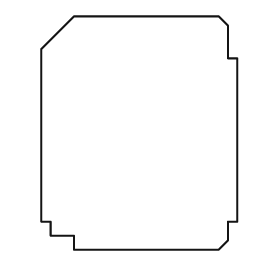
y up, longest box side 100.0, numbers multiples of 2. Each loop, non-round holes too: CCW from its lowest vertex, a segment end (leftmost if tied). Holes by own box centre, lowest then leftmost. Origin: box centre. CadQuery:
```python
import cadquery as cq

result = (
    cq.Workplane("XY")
    .moveTo(-28.0, -50.0)
    .lineTo(34.0, -50.0)
    .lineTo(38.0, -46.0)
    .lineTo(38.0, -38.0)
    .lineTo(42.0, -38.0)
    .lineTo(42.0, 32.0)
    .lineTo(38.0, 32.0)
    .lineTo(38.0, 46.0)
    .lineTo(34.0, 50.0)
    .lineTo(-28.0, 50.0)
    .lineTo(-42.0, 36.0)
    .lineTo(-42.0, -38.0)
    .lineTo(-38.0, -38.0)
    .lineTo(-38.0, -44.0)
    .lineTo(-28.0, -44.0)
    .close()
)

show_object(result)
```